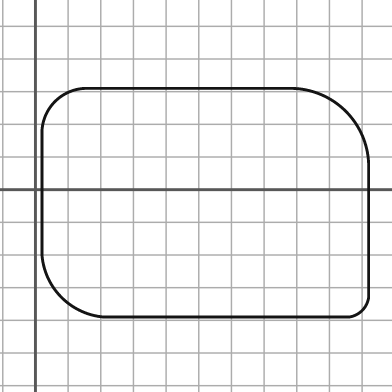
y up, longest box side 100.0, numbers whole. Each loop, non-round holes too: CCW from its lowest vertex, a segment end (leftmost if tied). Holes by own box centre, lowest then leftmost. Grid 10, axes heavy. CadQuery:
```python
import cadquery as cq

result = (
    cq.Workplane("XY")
    .moveTo(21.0, -39.0)
    .lineTo(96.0, -39.0)
    .threePointArc((100.0, -37.0), (102.0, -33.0))
    .lineTo(102.0, 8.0)
    .threePointArc((95.0, 24.0), (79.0, 31.0))
    .lineTo(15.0, 31.0)
    .threePointArc((6.0, 27.0), (2.0, 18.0))
    .lineTo(2.0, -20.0)
    .threePointArc((8.0, -33.0), (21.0, -39.0))
    .close()
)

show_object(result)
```